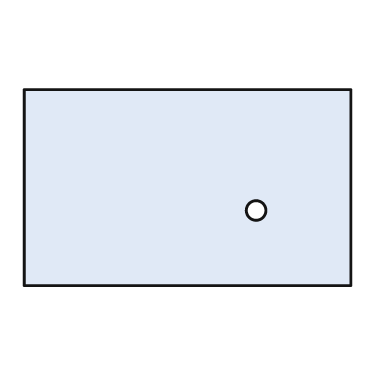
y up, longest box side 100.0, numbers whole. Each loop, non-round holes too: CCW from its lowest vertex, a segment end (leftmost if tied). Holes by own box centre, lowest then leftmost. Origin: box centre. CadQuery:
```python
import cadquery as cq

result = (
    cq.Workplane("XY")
    .moveTo(-50.0, -30.0)
    .lineTo(50.0, -30.0)
    .lineTo(50.0, 30.0)
    .lineTo(-50.0, 30.0)
    .close()
    .moveTo(21.0, -7.0)
    .circle(3.0)
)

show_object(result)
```